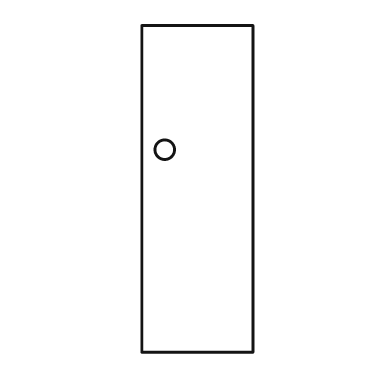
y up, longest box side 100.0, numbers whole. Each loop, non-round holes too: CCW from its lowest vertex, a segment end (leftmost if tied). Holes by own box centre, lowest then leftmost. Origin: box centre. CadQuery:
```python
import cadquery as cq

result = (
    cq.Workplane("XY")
    .moveTo(-17.0, -50.0)
    .lineTo(17.0, -50.0)
    .lineTo(17.0, 50.0)
    .lineTo(-17.0, 50.0)
    .close()
    .moveTo(-10.0, 12.0)
    .circle(3.0)
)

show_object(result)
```